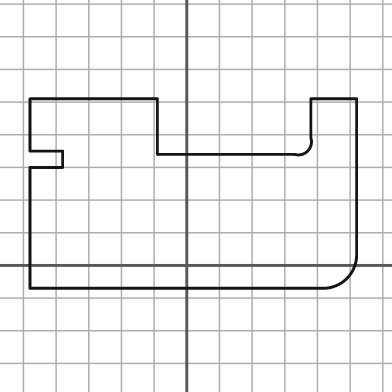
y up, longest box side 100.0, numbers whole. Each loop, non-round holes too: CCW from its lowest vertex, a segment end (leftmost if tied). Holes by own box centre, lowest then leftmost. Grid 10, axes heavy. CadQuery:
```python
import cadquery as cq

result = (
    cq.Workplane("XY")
    .moveTo(-48.0, -7.0)
    .lineTo(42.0, -7.0)
    .threePointArc((49.0, -4.0), (52.0, 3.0))
    .lineTo(52.0, 51.0)
    .lineTo(38.0, 51.0)
    .lineTo(38.0, 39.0)
    .threePointArc((37.0, 35.0), (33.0, 34.0))
    .lineTo(-9.0, 34.0)
    .lineTo(-9.0, 51.0)
    .lineTo(-48.0, 51.0)
    .lineTo(-48.0, 35.0)
    .lineTo(-38.0, 35.0)
    .lineTo(-38.0, 30.0)
    .lineTo(-48.0, 30.0)
    .close()
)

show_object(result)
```